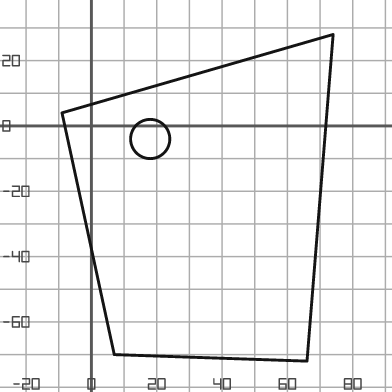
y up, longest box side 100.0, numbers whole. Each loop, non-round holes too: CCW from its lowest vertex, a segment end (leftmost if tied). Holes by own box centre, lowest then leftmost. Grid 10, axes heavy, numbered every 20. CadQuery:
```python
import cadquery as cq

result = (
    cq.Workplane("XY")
    .moveTo(66.0, -72.0)
    .lineTo(74.0, 28.0)
    .lineTo(-9.0, 4.0)
    .lineTo(7.0, -70.0)
    .close()
    .moveTo(18.0, -4.0)
    .circle(6.0)
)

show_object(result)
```